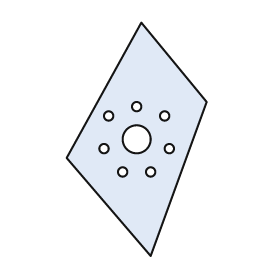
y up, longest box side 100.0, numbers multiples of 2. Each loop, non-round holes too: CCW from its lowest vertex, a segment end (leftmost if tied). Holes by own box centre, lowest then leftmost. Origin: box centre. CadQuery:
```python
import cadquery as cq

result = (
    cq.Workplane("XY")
    .moveTo(6.0, -50.0)
    .lineTo(30.0, 16.0)
    .lineTo(2.0, 50.0)
    .lineTo(-30.0, -8.0)
    .close()
    .moveTo(-6.0, -14.0)
    .circle(2.0)
    .moveTo(6.0, -14.0)
    .circle(2.0)
    .moveTo(-14.0, -4.0)
    .circle(2.0)
    .moveTo(14.0, -4.0)
    .circle(2.0)
    .moveTo(0.0, 0.0)
    .circle(6.0)
    .moveTo(-12.0, 10.0)
    .circle(2.0)
    .moveTo(12.0, 10.0)
    .circle(2.0)
    .moveTo(0.0, 14.0)
    .circle(2.0)
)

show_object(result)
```